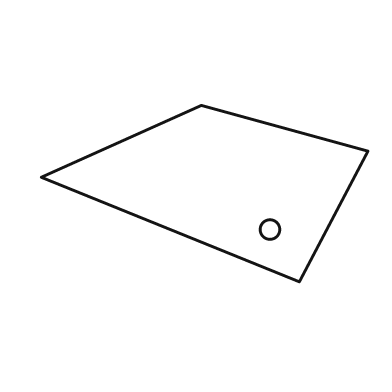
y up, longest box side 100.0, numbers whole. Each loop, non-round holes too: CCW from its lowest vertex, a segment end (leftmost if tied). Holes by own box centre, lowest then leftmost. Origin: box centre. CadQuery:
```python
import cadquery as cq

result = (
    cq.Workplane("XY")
    .moveTo(29.0, -27.0)
    .lineTo(50.0, 13.0)
    .lineTo(-1.0, 27.0)
    .lineTo(-50.0, 5.0)
    .close()
    .moveTo(20.0, -11.0)
    .circle(3.0)
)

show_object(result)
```